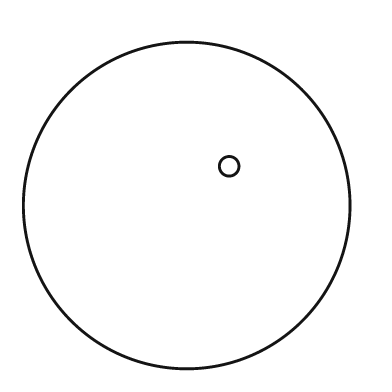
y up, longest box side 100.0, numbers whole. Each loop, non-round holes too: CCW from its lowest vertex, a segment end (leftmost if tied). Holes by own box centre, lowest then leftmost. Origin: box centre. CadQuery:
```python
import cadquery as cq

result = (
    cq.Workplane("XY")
    .moveTo(0.0, 0.0)
    .circle(50.0)
    .moveTo(13.0, 12.0)
    .circle(3.0)
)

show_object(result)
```